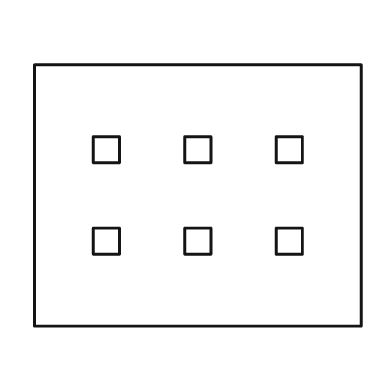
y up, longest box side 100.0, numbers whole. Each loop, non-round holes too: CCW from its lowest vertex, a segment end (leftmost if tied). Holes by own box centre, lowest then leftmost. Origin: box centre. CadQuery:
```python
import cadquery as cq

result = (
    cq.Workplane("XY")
    .moveTo(-50.0, -40.0)
    .lineTo(50.0, -40.0)
    .lineTo(50.0, 40.0)
    .lineTo(-50.0, 40.0)
    .close()
    .moveTo(-32.0, -18.0)
    .lineTo(-24.0, -18.0)
    .lineTo(-24.0, -10.0)
    .lineTo(-32.0, -10.0)
    .close()
    .moveTo(-4.0, -18.0)
    .lineTo(4.0, -18.0)
    .lineTo(4.0, -10.0)
    .lineTo(-4.0, -10.0)
    .close()
    .moveTo(24.0, -18.0)
    .lineTo(32.0, -18.0)
    .lineTo(32.0, -10.0)
    .lineTo(24.0, -10.0)
    .close()
    .moveTo(-32.0, 10.0)
    .lineTo(-24.0, 10.0)
    .lineTo(-24.0, 18.0)
    .lineTo(-32.0, 18.0)
    .close()
    .moveTo(-4.0, 10.0)
    .lineTo(4.0, 10.0)
    .lineTo(4.0, 18.0)
    .lineTo(-4.0, 18.0)
    .close()
    .moveTo(24.0, 10.0)
    .lineTo(32.0, 10.0)
    .lineTo(32.0, 18.0)
    .lineTo(24.0, 18.0)
    .close()
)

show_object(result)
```